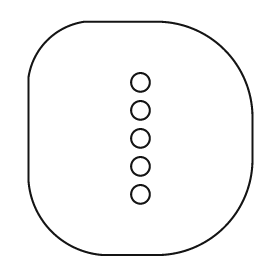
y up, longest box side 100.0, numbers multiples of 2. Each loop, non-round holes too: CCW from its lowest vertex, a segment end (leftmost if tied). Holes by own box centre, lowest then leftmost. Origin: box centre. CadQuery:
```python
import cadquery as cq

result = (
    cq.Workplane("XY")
    .moveTo(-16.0, -50.0)
    .lineTo(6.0, -50.0)
    .threePointArc((36.0, -38.0), (48.0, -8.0))
    .lineTo(48.0, 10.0)
    .threePointArc((36.0, 38.0), (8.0, 50.0))
    .lineTo(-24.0, 50.0)
    .threePointArc((-40.0, 42.0), (-48.0, 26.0))
    .lineTo(-48.0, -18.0)
    .threePointArc((-38.0, -40.0), (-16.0, -50.0))
    .close()
    .moveTo(0.0, -24.0)
    .circle(4.0)
    .moveTo(0.0, -12.0)
    .circle(4.0)
    .moveTo(0.0, 0.0)
    .circle(4.0)
    .moveTo(0.0, 12.0)
    .circle(4.0)
    .moveTo(0.0, 24.0)
    .circle(4.0)
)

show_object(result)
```